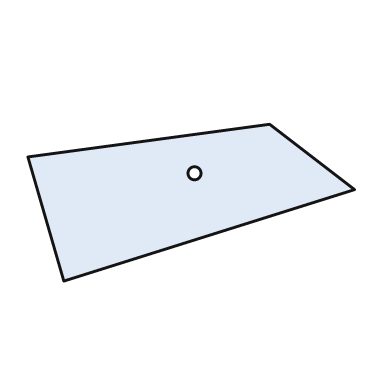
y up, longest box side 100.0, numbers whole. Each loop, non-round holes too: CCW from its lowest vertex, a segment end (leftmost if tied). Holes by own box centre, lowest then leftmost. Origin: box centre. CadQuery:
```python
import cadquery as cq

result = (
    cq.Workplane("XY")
    .moveTo(-39.0, -24.0)
    .lineTo(50.0, 4.0)
    .lineTo(24.0, 24.0)
    .lineTo(-50.0, 14.0)
    .close()
    .moveTo(1.0, 9.0)
    .circle(2.0)
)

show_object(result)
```